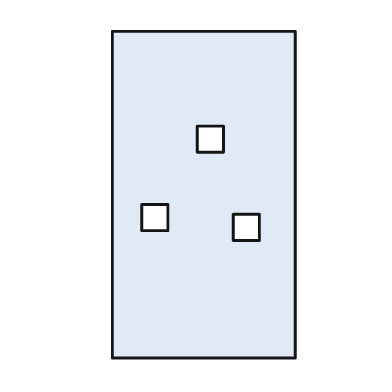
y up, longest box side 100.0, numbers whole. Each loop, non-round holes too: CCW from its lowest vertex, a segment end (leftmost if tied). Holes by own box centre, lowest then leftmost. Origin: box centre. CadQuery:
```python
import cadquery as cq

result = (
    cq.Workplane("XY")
    .moveTo(-28.0, -50.0)
    .lineTo(28.0, -50.0)
    .lineTo(28.0, 50.0)
    .lineTo(-28.0, 50.0)
    .close()
    .moveTo(9.0, -14.0)
    .lineTo(17.0, -14.0)
    .lineTo(17.0, -6.0)
    .lineTo(9.0, -6.0)
    .close()
    .moveTo(-19.0, -11.0)
    .lineTo(-11.0, -11.0)
    .lineTo(-11.0, -3.0)
    .lineTo(-19.0, -3.0)
    .close()
    .moveTo(-2.0, 13.0)
    .lineTo(6.0, 13.0)
    .lineTo(6.0, 21.0)
    .lineTo(-2.0, 21.0)
    .close()
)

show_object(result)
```